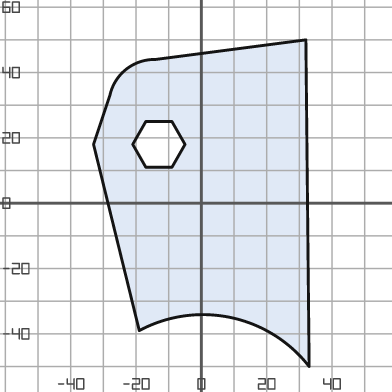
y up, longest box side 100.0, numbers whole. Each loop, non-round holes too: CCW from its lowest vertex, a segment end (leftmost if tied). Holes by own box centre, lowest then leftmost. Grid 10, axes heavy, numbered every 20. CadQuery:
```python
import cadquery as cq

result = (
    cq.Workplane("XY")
    .moveTo(33.0, -50.0)
    .lineTo(32.0, 50.0)
    .lineTo(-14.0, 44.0)
    .threePointArc((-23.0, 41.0), (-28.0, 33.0))
    .lineTo(-33.0, 18.0)
    .lineTo(-19.0, -39.0)
    .threePointArc((9.0, -35.0), (33.0, -50.0))
    .close()
    .moveTo(-17.0, 11.0)
    .lineTo(-9.0, 11.0)
    .lineTo(-5.0, 18.0)
    .lineTo(-9.0, 25.0)
    .lineTo(-17.0, 25.0)
    .lineTo(-21.0, 18.0)
    .close()
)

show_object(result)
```